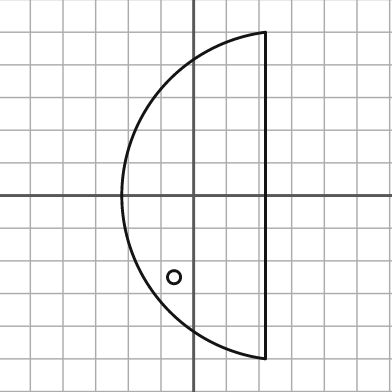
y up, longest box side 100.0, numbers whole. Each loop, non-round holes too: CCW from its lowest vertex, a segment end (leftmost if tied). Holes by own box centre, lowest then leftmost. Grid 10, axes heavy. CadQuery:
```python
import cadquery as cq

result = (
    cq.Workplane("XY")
    .moveTo(22.0, -50.0)
    .lineTo(22.0, 50.0)
    .threePointArc((-22.0, 0.0), (22.0, -50.0))
    .close()
    .moveTo(-6.0, -25.0)
    .circle(2.0)
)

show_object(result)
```